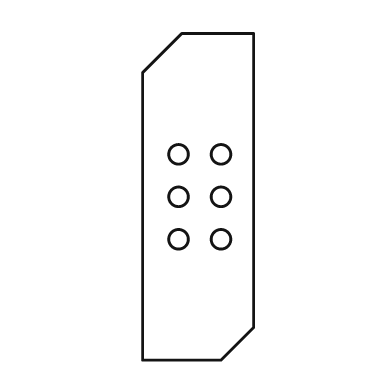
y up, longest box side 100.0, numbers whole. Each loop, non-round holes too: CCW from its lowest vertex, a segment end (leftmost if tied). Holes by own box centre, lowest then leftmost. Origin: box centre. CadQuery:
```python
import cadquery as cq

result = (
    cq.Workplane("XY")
    .moveTo(-17.0, -50.0)
    .lineTo(7.0, -50.0)
    .lineTo(17.0, -40.0)
    .lineTo(17.0, 50.0)
    .lineTo(-5.0, 50.0)
    .lineTo(-17.0, 38.0)
    .close()
    .moveTo(-6.0, -13.0)
    .circle(3.0)
    .moveTo(7.0, -13.0)
    .circle(3.0)
    .moveTo(-6.0, 0.0)
    .circle(3.0)
    .moveTo(7.0, 0.0)
    .circle(3.0)
    .moveTo(-6.0, 13.0)
    .circle(3.0)
    .moveTo(7.0, 13.0)
    .circle(3.0)
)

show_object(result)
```